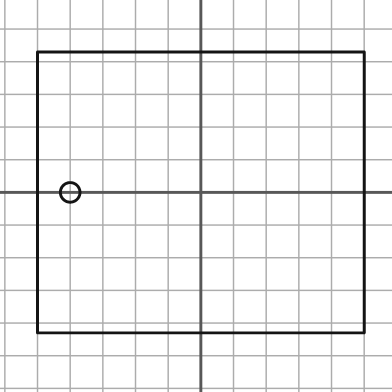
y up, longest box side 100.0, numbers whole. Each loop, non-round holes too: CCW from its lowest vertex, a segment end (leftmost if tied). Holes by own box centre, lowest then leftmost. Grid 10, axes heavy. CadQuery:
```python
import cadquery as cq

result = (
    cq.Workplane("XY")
    .moveTo(-50.0, -43.0)
    .lineTo(50.0, -43.0)
    .lineTo(50.0, 43.0)
    .lineTo(-50.0, 43.0)
    .close()
    .moveTo(-40.0, 0.0)
    .circle(3.0)
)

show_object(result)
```